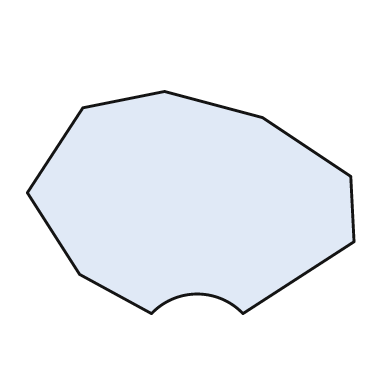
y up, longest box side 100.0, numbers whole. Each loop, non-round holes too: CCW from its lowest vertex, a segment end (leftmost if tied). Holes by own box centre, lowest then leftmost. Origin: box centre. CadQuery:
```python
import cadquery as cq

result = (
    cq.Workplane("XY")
    .moveTo(-12.0, -34.0)
    .threePointArc((2.0, -28.0), (16.0, -34.0))
    .lineTo(50.0, -12.0)
    .lineTo(49.0, 8.0)
    .lineTo(22.0, 26.0)
    .lineTo(-8.0, 34.0)
    .lineTo(-33.0, 29.0)
    .lineTo(-50.0, 3.0)
    .lineTo(-34.0, -22.0)
    .close()
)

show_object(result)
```